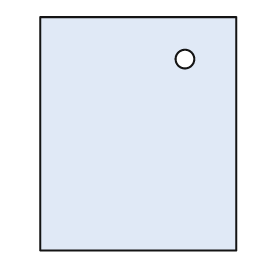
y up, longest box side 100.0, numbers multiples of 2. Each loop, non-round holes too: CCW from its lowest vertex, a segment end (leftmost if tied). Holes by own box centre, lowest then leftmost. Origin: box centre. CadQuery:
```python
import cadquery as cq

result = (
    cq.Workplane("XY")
    .moveTo(-42.0, -50.0)
    .lineTo(42.0, -50.0)
    .lineTo(42.0, 50.0)
    .lineTo(-42.0, 50.0)
    .close()
    .moveTo(20.0, 32.0)
    .circle(4.0)
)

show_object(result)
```